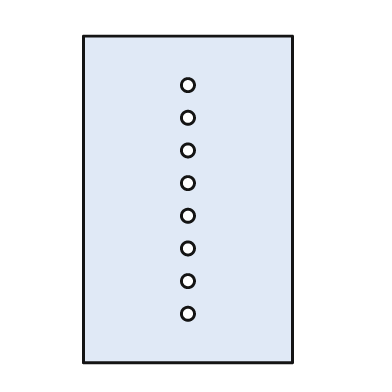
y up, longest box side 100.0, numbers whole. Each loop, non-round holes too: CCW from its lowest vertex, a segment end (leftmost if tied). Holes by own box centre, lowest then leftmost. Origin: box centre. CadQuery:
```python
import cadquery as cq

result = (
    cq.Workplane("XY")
    .moveTo(-32.0, -50.0)
    .lineTo(32.0, -50.0)
    .lineTo(32.0, 50.0)
    .lineTo(-32.0, 50.0)
    .close()
    .moveTo(0.0, -35.0)
    .circle(2.0)
    .moveTo(0.0, -25.0)
    .circle(2.0)
    .moveTo(0.0, -15.0)
    .circle(2.0)
    .moveTo(0.0, -5.0)
    .circle(2.0)
    .moveTo(0.0, 5.0)
    .circle(2.0)
    .moveTo(0.0, 15.0)
    .circle(2.0)
    .moveTo(0.0, 25.0)
    .circle(2.0)
    .moveTo(0.0, 35.0)
    .circle(2.0)
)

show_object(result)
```